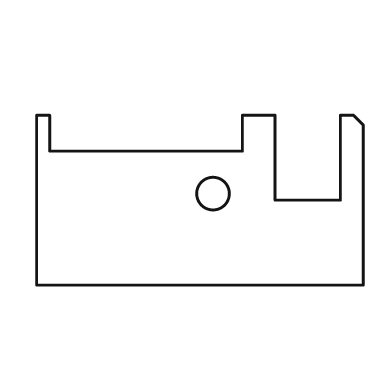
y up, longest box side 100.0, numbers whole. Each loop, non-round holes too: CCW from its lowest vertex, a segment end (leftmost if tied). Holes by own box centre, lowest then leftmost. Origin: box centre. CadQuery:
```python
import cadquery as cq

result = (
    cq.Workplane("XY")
    .moveTo(-50.0, -26.0)
    .lineTo(50.0, -26.0)
    .lineTo(50.0, 23.0)
    .lineTo(47.0, 26.0)
    .lineTo(43.0, 26.0)
    .lineTo(43.0, 0.0)
    .lineTo(23.0, 0.0)
    .lineTo(23.0, 26.0)
    .lineTo(13.0, 26.0)
    .lineTo(13.0, 15.0)
    .lineTo(-46.0, 15.0)
    .lineTo(-46.0, 26.0)
    .lineTo(-50.0, 26.0)
    .close()
    .moveTo(4.0, 2.0)
    .circle(5.0)
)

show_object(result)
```